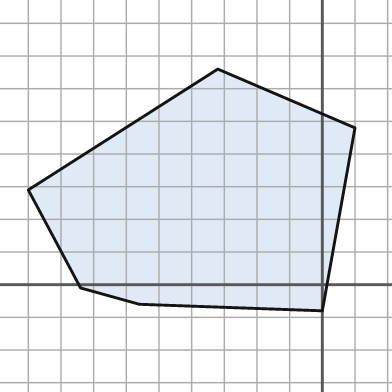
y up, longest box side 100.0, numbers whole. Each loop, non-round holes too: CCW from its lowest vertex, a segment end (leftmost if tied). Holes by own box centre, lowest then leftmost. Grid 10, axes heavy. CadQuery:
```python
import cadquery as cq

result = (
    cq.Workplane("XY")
    .moveTo(0.0, -8.0)
    .lineTo(10.0, 48.0)
    .lineTo(-32.0, 66.0)
    .lineTo(-90.0, 29.0)
    .lineTo(-74.0, -1.0)
    .lineTo(-56.0, -6.0)
    .close()
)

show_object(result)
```